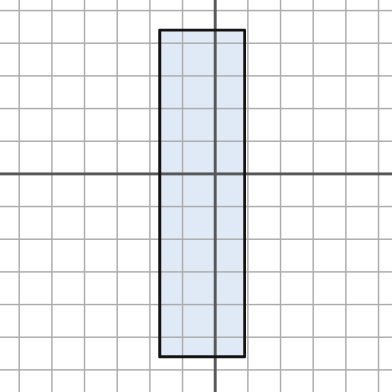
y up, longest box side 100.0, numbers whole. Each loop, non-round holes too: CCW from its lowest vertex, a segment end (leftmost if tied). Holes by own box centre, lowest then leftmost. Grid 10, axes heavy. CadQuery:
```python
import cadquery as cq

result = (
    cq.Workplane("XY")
    .moveTo(-17.0, -56.0)
    .lineTo(9.0, -56.0)
    .lineTo(9.0, 44.0)
    .lineTo(-17.0, 44.0)
    .close()
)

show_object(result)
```